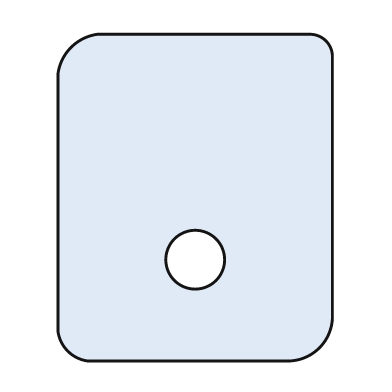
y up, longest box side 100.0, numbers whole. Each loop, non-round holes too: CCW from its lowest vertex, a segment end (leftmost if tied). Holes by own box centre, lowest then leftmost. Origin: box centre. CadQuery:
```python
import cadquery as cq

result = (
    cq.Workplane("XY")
    .moveTo(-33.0, -50.0)
    .lineTo(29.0, -50.0)
    .threePointArc((38.0, -46.0), (42.0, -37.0))
    .lineTo(42.0, 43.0)
    .threePointArc((40.0, 48.0), (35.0, 50.0))
    .lineTo(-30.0, 50.0)
    .threePointArc((-38.0, 46.0), (-42.0, 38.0))
    .lineTo(-42.0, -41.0)
    .threePointArc((-39.0, -47.0), (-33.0, -50.0))
    .close()
    .moveTo(0.0, -19.0)
    .circle(9.0)
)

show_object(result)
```